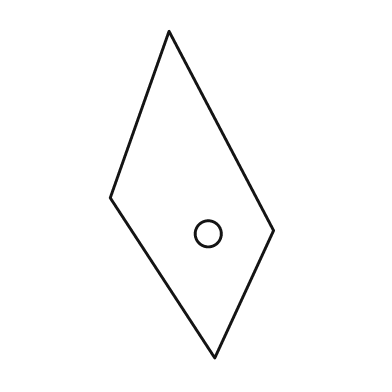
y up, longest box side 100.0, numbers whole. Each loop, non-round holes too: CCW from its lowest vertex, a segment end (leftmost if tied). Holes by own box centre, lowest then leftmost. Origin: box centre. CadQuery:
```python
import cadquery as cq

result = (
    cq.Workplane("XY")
    .moveTo(7.0, -50.0)
    .lineTo(25.0, -11.0)
    .lineTo(-7.0, 50.0)
    .lineTo(-25.0, -1.0)
    .close()
    .moveTo(5.0, -12.0)
    .circle(4.0)
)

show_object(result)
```